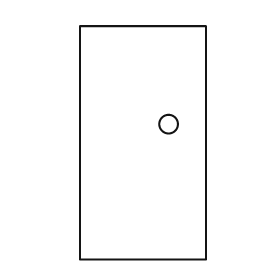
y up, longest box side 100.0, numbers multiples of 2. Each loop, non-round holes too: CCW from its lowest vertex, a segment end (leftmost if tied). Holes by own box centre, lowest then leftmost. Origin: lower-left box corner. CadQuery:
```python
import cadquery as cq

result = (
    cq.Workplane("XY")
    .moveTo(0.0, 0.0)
    .lineTo(54.0, 0.0)
    .lineTo(54.0, 100.0)
    .lineTo(0.0, 100.0)
    .close()
    .moveTo(38.0, 58.0)
    .circle(4.0)
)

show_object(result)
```